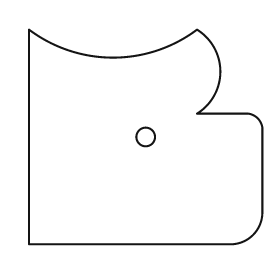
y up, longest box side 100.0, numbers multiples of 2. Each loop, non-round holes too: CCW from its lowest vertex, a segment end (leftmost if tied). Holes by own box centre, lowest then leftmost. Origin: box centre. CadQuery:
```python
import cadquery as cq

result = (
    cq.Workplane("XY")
    .moveTo(-50.0, -46.0)
    .lineTo(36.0, -46.0)
    .threePointArc((46.0, -42.0), (50.0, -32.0))
    .lineTo(50.0, 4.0)
    .threePointArc((48.0, 8.0), (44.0, 10.0))
    .lineTo(22.0, 10.0)
    .threePointArc((32.0, 28.0), (22.0, 46.0))
    .threePointArc((-14.0, 34.0), (-50.0, 46.0))
    .close()
    .moveTo(0.0, 0.0)
    .circle(4.0)
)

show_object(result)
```